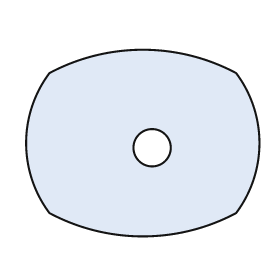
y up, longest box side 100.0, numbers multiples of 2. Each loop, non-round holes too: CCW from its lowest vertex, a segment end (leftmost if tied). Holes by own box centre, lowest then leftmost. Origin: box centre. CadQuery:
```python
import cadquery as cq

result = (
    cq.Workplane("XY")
    .moveTo(-40.0, -30.0)
    .threePointArc((0.0, -40.0), (40.0, -30.0))
    .threePointArc((50.0, 0.0), (40.0, 30.0))
    .threePointArc((0.0, 40.0), (-40.0, 30.0))
    .threePointArc((-50.0, 0.0), (-40.0, -30.0))
    .close()
    .moveTo(4.0, -2.0)
    .circle(8.0)
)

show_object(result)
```